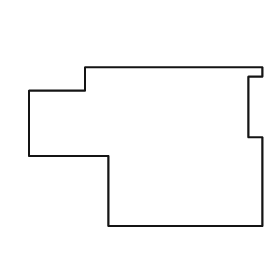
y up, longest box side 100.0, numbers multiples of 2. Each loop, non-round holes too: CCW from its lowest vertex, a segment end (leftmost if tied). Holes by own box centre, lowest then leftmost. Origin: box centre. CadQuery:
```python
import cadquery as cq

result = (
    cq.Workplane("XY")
    .moveTo(-16.0, -34.0)
    .lineTo(50.0, -34.0)
    .lineTo(50.0, 4.0)
    .lineTo(44.0, 4.0)
    .lineTo(44.0, 30.0)
    .lineTo(50.0, 30.0)
    .lineTo(50.0, 34.0)
    .lineTo(-26.0, 34.0)
    .lineTo(-26.0, 24.0)
    .lineTo(-50.0, 24.0)
    .lineTo(-50.0, -4.0)
    .lineTo(-16.0, -4.0)
    .close()
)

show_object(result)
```